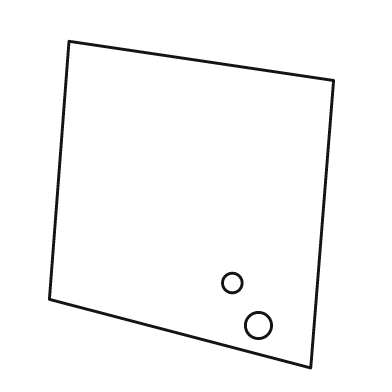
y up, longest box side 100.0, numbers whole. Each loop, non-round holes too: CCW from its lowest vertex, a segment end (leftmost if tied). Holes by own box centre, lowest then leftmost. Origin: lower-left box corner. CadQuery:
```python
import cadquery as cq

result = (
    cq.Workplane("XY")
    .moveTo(80.0, 0.0)
    .lineTo(87.0, 88.0)
    .lineTo(6.0, 100.0)
    .lineTo(0.0, 21.0)
    .close()
    .moveTo(64.0, 13.0)
    .circle(4.0)
    .moveTo(56.0, 26.0)
    .circle(3.0)
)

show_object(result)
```